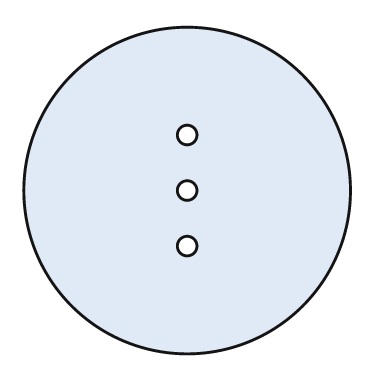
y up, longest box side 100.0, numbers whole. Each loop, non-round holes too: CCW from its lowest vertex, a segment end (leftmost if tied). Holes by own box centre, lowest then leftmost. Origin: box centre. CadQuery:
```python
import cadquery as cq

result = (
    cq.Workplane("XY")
    .moveTo(0.0, 0.0)
    .circle(50.0)
    .moveTo(0.0, -17.0)
    .circle(3.0)
    .moveTo(0.0, 0.0)
    .circle(3.0)
    .moveTo(0.0, 17.0)
    .circle(3.0)
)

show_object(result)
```